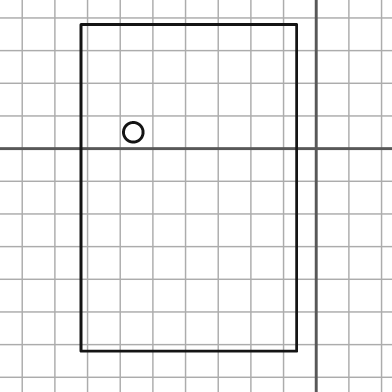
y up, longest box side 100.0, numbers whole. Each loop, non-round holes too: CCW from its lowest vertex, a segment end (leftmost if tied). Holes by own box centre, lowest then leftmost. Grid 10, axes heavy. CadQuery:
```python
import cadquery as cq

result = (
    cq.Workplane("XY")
    .moveTo(-72.0, -62.0)
    .lineTo(-6.0, -62.0)
    .lineTo(-6.0, 38.0)
    .lineTo(-72.0, 38.0)
    .close()
    .moveTo(-56.0, 5.0)
    .circle(3.0)
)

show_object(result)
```